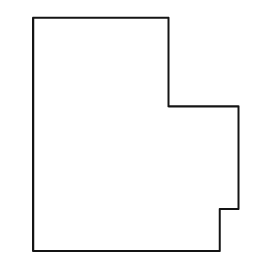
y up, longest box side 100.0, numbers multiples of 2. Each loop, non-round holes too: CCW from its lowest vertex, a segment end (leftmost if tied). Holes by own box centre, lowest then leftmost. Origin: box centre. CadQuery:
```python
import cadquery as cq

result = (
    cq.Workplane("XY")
    .moveTo(-44.0, -50.0)
    .lineTo(36.0, -50.0)
    .lineTo(36.0, -32.0)
    .lineTo(44.0, -32.0)
    .lineTo(44.0, 12.0)
    .lineTo(14.0, 12.0)
    .lineTo(14.0, 50.0)
    .lineTo(-44.0, 50.0)
    .close()
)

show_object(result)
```